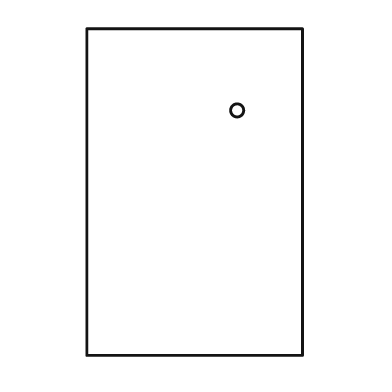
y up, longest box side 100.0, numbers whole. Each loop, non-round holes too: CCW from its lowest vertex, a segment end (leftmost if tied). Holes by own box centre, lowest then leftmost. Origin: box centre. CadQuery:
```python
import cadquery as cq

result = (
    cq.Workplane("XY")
    .moveTo(-33.0, -50.0)
    .lineTo(33.0, -50.0)
    .lineTo(33.0, 50.0)
    .lineTo(-33.0, 50.0)
    .close()
    .moveTo(13.0, 25.0)
    .circle(2.0)
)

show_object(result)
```